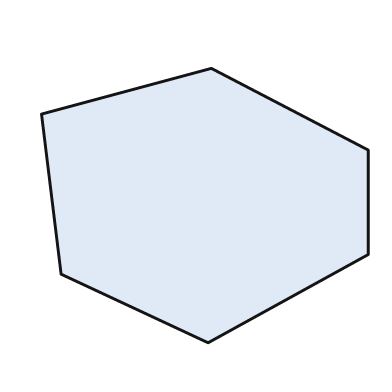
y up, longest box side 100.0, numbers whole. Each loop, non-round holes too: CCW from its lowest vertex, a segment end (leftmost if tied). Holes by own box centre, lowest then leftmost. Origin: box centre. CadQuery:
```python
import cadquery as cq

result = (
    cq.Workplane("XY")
    .moveTo(1.0, -42.0)
    .lineTo(50.0, -15.0)
    .lineTo(50.0, 17.0)
    .lineTo(2.0, 42.0)
    .lineTo(-50.0, 28.0)
    .lineTo(-44.0, -21.0)
    .close()
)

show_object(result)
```